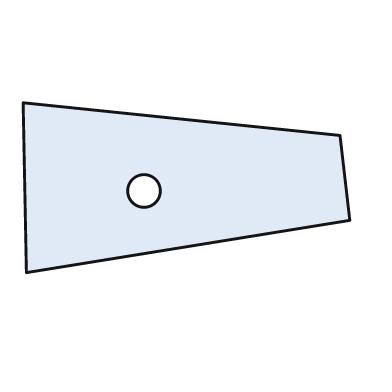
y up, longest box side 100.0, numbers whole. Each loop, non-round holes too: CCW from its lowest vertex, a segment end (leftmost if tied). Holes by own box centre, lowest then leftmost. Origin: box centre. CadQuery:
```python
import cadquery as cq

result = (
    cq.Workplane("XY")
    .moveTo(-49.0, -26.0)
    .lineTo(50.0, -10.0)
    .lineTo(47.0, 16.0)
    .lineTo(-50.0, 26.0)
    .close()
    .moveTo(-13.0, -1.0)
    .circle(5.0)
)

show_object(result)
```